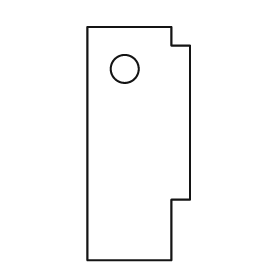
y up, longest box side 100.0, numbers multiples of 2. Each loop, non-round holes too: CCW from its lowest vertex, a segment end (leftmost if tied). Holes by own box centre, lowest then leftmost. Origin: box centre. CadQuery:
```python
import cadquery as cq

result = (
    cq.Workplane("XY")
    .moveTo(-22.0, -50.0)
    .lineTo(14.0, -50.0)
    .lineTo(14.0, -24.0)
    .lineTo(22.0, -24.0)
    .lineTo(22.0, 42.0)
    .lineTo(14.0, 42.0)
    .lineTo(14.0, 50.0)
    .lineTo(-22.0, 50.0)
    .close()
    .moveTo(-6.0, 32.0)
    .circle(6.0)
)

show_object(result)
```